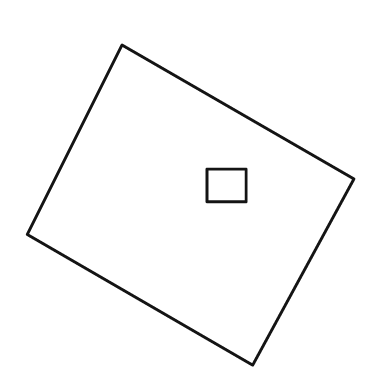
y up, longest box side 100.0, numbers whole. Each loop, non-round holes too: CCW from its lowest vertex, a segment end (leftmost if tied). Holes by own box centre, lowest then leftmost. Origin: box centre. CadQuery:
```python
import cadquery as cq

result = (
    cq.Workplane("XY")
    .moveTo(19.0, -49.0)
    .lineTo(50.0, 8.0)
    .lineTo(-21.0, 49.0)
    .lineTo(-50.0, -9.0)
    .close()
    .moveTo(5.0, 1.0)
    .lineTo(17.0, 1.0)
    .lineTo(17.0, 11.0)
    .lineTo(5.0, 11.0)
    .close()
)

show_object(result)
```